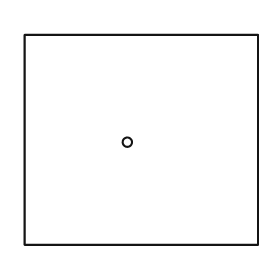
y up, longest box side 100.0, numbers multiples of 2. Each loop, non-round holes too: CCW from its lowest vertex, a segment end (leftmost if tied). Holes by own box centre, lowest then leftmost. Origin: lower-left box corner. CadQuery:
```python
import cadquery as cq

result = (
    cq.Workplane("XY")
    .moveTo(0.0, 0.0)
    .lineTo(100.0, 0.0)
    .lineTo(100.0, 90.0)
    .lineTo(0.0, 90.0)
    .close()
    .moveTo(44.0, 44.0)
    .circle(2.0)
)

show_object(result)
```